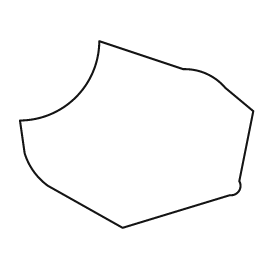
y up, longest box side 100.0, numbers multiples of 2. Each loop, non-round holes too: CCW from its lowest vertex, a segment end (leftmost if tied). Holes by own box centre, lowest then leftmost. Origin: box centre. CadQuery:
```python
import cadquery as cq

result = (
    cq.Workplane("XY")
    .moveTo(-6.0, -40.0)
    .lineTo(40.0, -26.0)
    .threePointArc((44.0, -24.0), (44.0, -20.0))
    .lineTo(50.0, 10.0)
    .lineTo(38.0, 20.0)
    .threePointArc((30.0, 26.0), (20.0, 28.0))
    .lineTo(-16.0, 40.0)
    .threePointArc((-26.0, 16.0), (-50.0, 6.0))
    .lineTo(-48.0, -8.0)
    .threePointArc((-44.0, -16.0), (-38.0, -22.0))
    .close()
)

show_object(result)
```